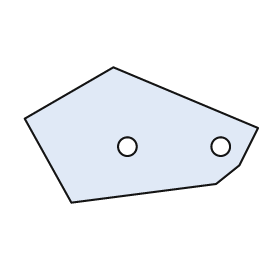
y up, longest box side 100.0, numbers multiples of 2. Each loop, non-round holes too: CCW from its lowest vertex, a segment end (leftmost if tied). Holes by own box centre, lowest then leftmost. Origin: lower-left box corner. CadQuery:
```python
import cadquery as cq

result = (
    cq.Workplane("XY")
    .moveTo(20.0, 0.0)
    .lineTo(82.0, 8.0)
    .lineTo(92.0, 16.0)
    .lineTo(100.0, 32.0)
    .lineTo(38.0, 58.0)
    .lineTo(0.0, 36.0)
    .close()
    .moveTo(44.0, 24.0)
    .circle(4.0)
    .moveTo(84.0, 24.0)
    .circle(4.0)
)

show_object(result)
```